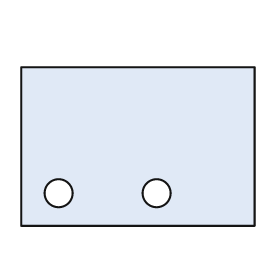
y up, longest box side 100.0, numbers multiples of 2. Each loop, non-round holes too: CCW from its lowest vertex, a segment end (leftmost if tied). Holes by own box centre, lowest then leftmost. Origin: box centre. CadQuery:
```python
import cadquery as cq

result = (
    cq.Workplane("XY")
    .moveTo(-50.0, -34.0)
    .lineTo(50.0, -34.0)
    .lineTo(50.0, 34.0)
    .lineTo(-50.0, 34.0)
    .close()
    .moveTo(-34.0, -20.0)
    .circle(6.0)
    .moveTo(8.0, -20.0)
    .circle(6.0)
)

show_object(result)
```